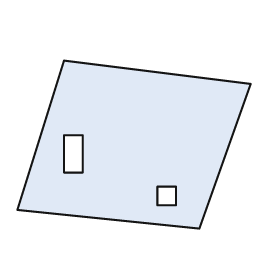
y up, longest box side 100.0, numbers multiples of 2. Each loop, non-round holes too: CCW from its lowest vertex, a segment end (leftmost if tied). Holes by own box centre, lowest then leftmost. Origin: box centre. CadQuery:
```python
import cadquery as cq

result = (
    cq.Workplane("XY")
    .moveTo(28.0, -36.0)
    .lineTo(50.0, 26.0)
    .lineTo(-30.0, 36.0)
    .lineTo(-50.0, -28.0)
    .close()
    .moveTo(10.0, -26.0)
    .lineTo(18.0, -26.0)
    .lineTo(18.0, -18.0)
    .lineTo(10.0, -18.0)
    .close()
    .moveTo(-30.0, -12.0)
    .lineTo(-22.0, -12.0)
    .lineTo(-22.0, 4.0)
    .lineTo(-30.0, 4.0)
    .close()
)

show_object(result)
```